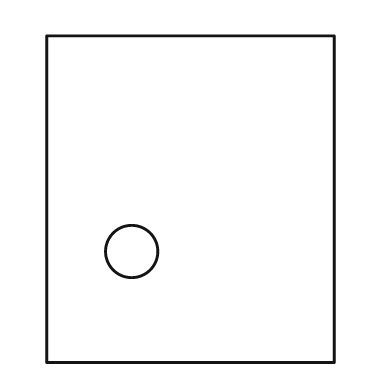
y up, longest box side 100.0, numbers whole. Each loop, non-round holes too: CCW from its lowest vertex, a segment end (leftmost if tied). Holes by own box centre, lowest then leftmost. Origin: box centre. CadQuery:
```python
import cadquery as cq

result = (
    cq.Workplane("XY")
    .moveTo(-44.0, -50.0)
    .lineTo(44.0, -50.0)
    .lineTo(44.0, 50.0)
    .lineTo(-44.0, 50.0)
    .close()
    .moveTo(-18.0, -16.0)
    .circle(8.0)
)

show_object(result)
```